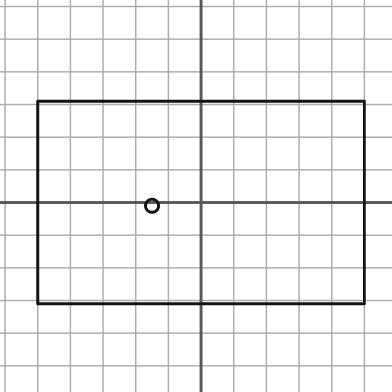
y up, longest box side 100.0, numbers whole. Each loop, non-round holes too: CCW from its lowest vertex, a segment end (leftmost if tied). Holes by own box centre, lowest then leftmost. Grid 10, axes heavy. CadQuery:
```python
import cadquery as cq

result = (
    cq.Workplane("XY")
    .moveTo(-50.0, -31.0)
    .lineTo(50.0, -31.0)
    .lineTo(50.0, 31.0)
    .lineTo(-50.0, 31.0)
    .close()
    .moveTo(-15.0, -1.0)
    .circle(2.0)
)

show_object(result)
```